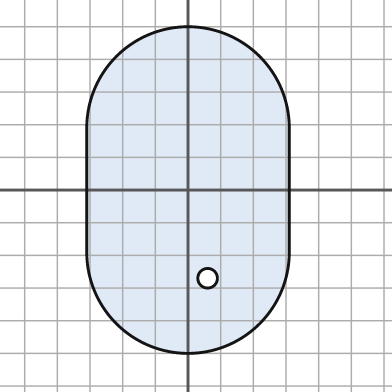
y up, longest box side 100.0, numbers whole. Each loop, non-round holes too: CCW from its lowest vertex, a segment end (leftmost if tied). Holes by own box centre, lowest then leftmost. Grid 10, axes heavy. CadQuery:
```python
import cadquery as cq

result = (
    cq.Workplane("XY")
    .moveTo(-31.0, -19.0)
    .threePointArc((0.0, -50.0), (31.0, -19.0))
    .lineTo(31.0, 19.0)
    .threePointArc((0.0, 50.0), (-31.0, 19.0))
    .close()
    .moveTo(6.0, -27.0)
    .circle(3.0)
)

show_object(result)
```